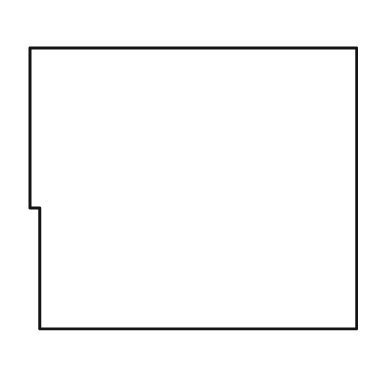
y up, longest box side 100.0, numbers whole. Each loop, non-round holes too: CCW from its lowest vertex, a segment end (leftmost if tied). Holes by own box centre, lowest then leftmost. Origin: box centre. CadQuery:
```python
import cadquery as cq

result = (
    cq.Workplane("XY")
    .moveTo(-47.0, -43.0)
    .lineTo(50.0, -43.0)
    .lineTo(50.0, 43.0)
    .lineTo(-50.0, 43.0)
    .lineTo(-50.0, -6.0)
    .lineTo(-47.0, -6.0)
    .close()
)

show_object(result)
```